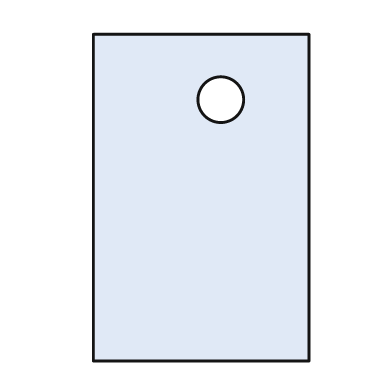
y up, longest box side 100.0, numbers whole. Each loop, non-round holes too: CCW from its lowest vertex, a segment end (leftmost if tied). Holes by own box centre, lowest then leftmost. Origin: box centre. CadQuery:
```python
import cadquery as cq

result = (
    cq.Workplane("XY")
    .moveTo(-33.0, -50.0)
    .lineTo(33.0, -50.0)
    .lineTo(33.0, 50.0)
    .lineTo(-33.0, 50.0)
    .close()
    .moveTo(6.0, 30.0)
    .circle(7.0)
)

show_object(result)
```